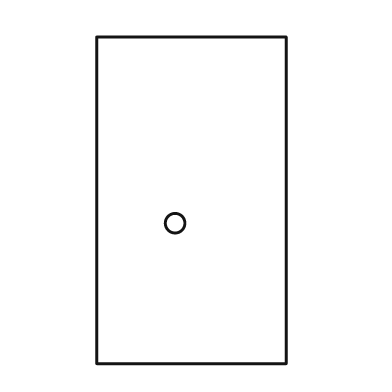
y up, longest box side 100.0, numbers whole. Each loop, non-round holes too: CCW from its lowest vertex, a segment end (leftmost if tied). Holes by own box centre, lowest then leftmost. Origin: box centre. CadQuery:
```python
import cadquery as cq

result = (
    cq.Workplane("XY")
    .moveTo(-29.0, -50.0)
    .lineTo(29.0, -50.0)
    .lineTo(29.0, 50.0)
    .lineTo(-29.0, 50.0)
    .close()
    .moveTo(-5.0, -7.0)
    .circle(3.0)
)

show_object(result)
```